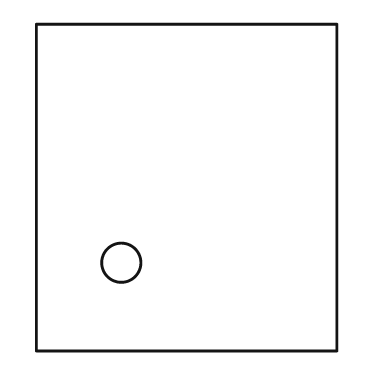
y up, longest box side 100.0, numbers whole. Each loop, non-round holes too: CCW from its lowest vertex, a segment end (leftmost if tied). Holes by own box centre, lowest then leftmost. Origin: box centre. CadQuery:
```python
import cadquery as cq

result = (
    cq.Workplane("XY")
    .moveTo(-46.0, -50.0)
    .lineTo(46.0, -50.0)
    .lineTo(46.0, 50.0)
    .lineTo(-46.0, 50.0)
    .close()
    .moveTo(-20.0, -23.0)
    .circle(6.0)
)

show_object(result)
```